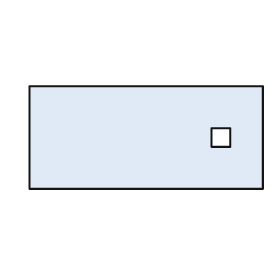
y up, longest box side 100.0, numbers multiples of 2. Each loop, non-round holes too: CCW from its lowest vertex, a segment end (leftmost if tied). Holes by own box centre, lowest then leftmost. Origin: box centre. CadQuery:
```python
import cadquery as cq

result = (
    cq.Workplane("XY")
    .moveTo(-50.0, -22.0)
    .lineTo(50.0, -22.0)
    .lineTo(50.0, 22.0)
    .lineTo(-50.0, 22.0)
    .close()
    .moveTo(28.0, -4.0)
    .lineTo(36.0, -4.0)
    .lineTo(36.0, 4.0)
    .lineTo(28.0, 4.0)
    .close()
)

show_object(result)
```